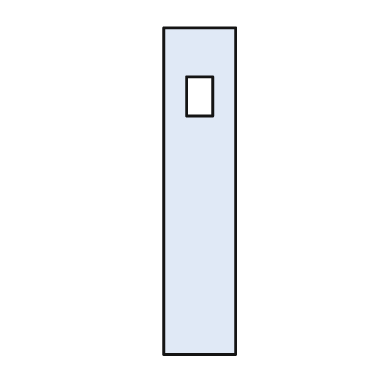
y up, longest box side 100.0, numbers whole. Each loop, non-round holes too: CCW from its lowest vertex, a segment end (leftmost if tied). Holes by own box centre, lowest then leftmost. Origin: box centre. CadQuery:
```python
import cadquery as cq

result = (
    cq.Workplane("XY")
    .moveTo(-11.0, -50.0)
    .lineTo(11.0, -50.0)
    .lineTo(11.0, 50.0)
    .lineTo(-11.0, 50.0)
    .close()
    .moveTo(-4.0, 23.0)
    .lineTo(4.0, 23.0)
    .lineTo(4.0, 35.0)
    .lineTo(-4.0, 35.0)
    .close()
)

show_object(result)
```